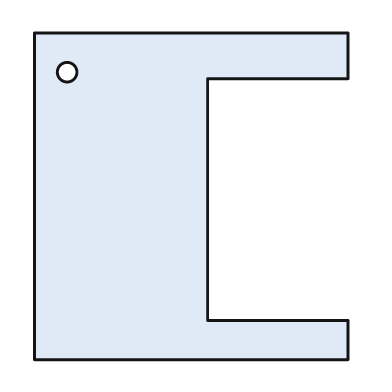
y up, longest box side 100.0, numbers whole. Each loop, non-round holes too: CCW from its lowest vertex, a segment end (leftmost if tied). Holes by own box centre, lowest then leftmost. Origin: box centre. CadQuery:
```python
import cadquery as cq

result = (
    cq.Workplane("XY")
    .moveTo(-48.0, -50.0)
    .lineTo(48.0, -50.0)
    .lineTo(48.0, -38.0)
    .lineTo(5.0, -38.0)
    .lineTo(5.0, 36.0)
    .lineTo(48.0, 36.0)
    .lineTo(48.0, 50.0)
    .lineTo(-48.0, 50.0)
    .close()
    .moveTo(-38.0, 38.0)
    .circle(3.0)
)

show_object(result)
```